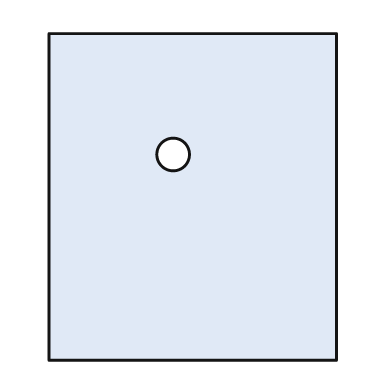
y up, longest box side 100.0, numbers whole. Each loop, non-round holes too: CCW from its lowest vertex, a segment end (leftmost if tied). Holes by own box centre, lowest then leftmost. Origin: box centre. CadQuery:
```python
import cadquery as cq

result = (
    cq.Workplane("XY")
    .moveTo(-44.0, -50.0)
    .lineTo(44.0, -50.0)
    .lineTo(44.0, 50.0)
    .lineTo(-44.0, 50.0)
    .close()
    .moveTo(-6.0, 13.0)
    .circle(5.0)
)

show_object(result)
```